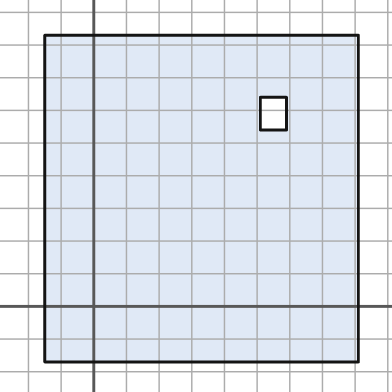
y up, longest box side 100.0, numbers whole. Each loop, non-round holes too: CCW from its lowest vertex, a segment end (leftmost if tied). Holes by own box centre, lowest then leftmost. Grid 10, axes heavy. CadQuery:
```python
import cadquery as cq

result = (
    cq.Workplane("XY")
    .moveTo(-15.0, -17.0)
    .lineTo(81.0, -17.0)
    .lineTo(81.0, 83.0)
    .lineTo(-15.0, 83.0)
    .close()
    .moveTo(51.0, 54.0)
    .lineTo(59.0, 54.0)
    .lineTo(59.0, 64.0)
    .lineTo(51.0, 64.0)
    .close()
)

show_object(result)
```